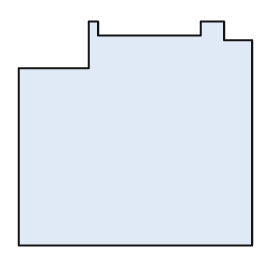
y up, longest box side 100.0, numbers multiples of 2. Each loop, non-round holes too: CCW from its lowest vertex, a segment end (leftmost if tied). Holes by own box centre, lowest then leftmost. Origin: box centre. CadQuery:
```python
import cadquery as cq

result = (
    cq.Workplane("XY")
    .moveTo(-50.0, -48.0)
    .lineTo(50.0, -48.0)
    .lineTo(50.0, 40.0)
    .lineTo(38.0, 40.0)
    .lineTo(38.0, 48.0)
    .lineTo(28.0, 48.0)
    .lineTo(28.0, 42.0)
    .lineTo(-16.0, 42.0)
    .lineTo(-16.0, 48.0)
    .lineTo(-20.0, 48.0)
    .lineTo(-20.0, 28.0)
    .lineTo(-50.0, 28.0)
    .close()
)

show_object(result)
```